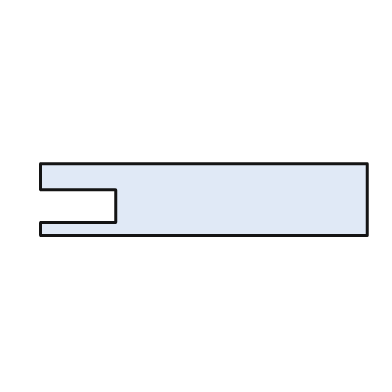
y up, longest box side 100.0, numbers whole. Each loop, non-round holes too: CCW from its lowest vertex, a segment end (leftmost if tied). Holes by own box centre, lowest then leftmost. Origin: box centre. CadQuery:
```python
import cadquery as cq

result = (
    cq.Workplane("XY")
    .moveTo(-50.0, -11.0)
    .lineTo(50.0, -11.0)
    .lineTo(50.0, 11.0)
    .lineTo(-50.0, 11.0)
    .lineTo(-50.0, 3.0)
    .lineTo(-27.0, 3.0)
    .lineTo(-27.0, -7.0)
    .lineTo(-50.0, -7.0)
    .close()
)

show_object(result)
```